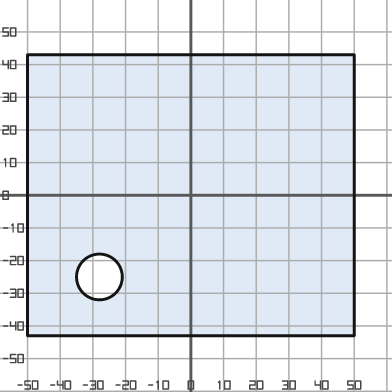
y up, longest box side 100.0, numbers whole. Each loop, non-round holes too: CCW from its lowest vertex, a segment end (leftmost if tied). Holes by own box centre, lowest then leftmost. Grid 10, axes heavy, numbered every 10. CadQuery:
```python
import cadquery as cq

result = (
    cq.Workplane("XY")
    .moveTo(-50.0, -43.0)
    .lineTo(50.0, -43.0)
    .lineTo(50.0, 43.0)
    .lineTo(-50.0, 43.0)
    .close()
    .moveTo(-28.0, -25.0)
    .circle(7.0)
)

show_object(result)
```